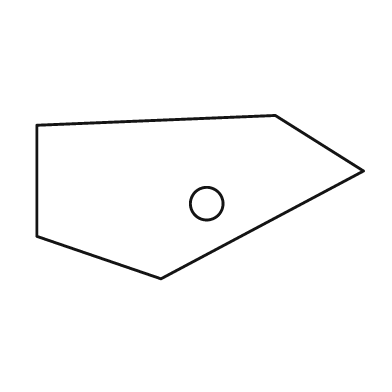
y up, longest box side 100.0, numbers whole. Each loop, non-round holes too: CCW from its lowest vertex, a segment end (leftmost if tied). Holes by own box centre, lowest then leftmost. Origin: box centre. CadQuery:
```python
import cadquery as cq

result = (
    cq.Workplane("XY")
    .moveTo(-12.0, -25.0)
    .lineTo(50.0, 8.0)
    .lineTo(23.0, 25.0)
    .lineTo(-50.0, 22.0)
    .lineTo(-50.0, -12.0)
    .close()
    .moveTo(2.0, -2.0)
    .circle(5.0)
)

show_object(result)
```